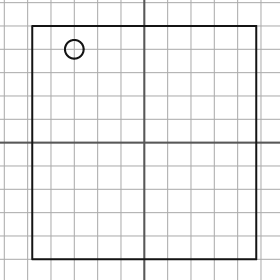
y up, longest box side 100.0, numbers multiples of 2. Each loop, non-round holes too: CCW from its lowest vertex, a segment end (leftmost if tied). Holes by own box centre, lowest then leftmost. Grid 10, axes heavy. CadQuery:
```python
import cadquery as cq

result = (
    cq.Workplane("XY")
    .moveTo(-48.0, -50.0)
    .lineTo(48.0, -50.0)
    .lineTo(48.0, 50.0)
    .lineTo(-48.0, 50.0)
    .close()
    .moveTo(-30.0, 40.0)
    .circle(4.0)
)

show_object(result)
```